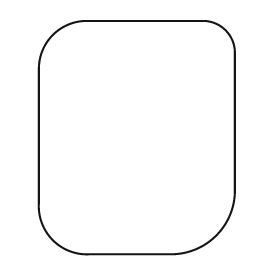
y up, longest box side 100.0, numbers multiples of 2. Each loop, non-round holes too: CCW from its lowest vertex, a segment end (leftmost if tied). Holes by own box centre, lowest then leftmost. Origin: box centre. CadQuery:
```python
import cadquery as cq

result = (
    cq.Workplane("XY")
    .moveTo(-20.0, -50.0)
    .lineTo(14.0, -50.0)
    .threePointArc((34.0, -42.0), (42.0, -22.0))
    .lineTo(42.0, 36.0)
    .threePointArc((38.0, 46.0), (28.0, 50.0))
    .lineTo(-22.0, 50.0)
    .threePointArc((-36.0, 44.0), (-42.0, 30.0))
    .lineTo(-42.0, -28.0)
    .threePointArc((-36.0, -44.0), (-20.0, -50.0))
    .close()
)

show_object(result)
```